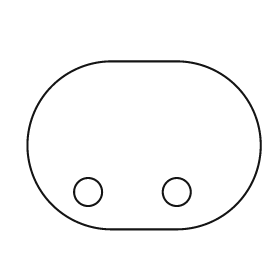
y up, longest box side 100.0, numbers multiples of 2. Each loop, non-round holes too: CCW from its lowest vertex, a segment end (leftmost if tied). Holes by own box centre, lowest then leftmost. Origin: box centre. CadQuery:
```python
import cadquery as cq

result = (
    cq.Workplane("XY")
    .moveTo(-14.0, -36.0)
    .lineTo(14.0, -36.0)
    .threePointArc((50.0, 0.0), (14.0, 36.0))
    .lineTo(-14.0, 36.0)
    .threePointArc((-50.0, 0.0), (-14.0, -36.0))
    .close()
    .moveTo(-24.0, -20.0)
    .circle(6.0)
    .moveTo(14.0, -20.0)
    .circle(6.0)
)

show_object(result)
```